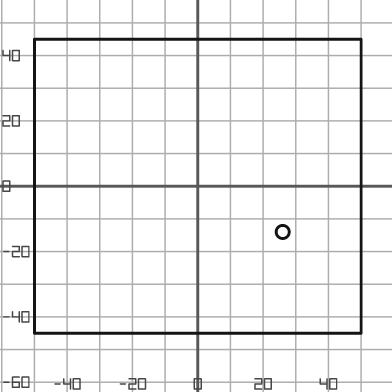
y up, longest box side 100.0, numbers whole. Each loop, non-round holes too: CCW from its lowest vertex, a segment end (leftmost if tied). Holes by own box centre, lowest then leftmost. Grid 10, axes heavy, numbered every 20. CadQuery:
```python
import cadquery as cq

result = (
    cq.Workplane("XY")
    .moveTo(-50.0, -45.0)
    .lineTo(50.0, -45.0)
    .lineTo(50.0, 45.0)
    .lineTo(-50.0, 45.0)
    .close()
    .moveTo(26.0, -14.0)
    .circle(2.0)
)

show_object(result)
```